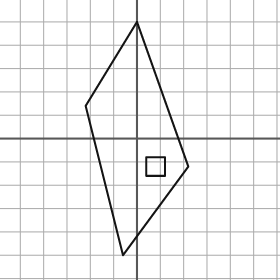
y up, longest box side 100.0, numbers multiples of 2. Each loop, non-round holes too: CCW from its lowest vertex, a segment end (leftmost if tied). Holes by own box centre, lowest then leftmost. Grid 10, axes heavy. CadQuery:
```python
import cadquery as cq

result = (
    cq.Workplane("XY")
    .moveTo(-6.0, -50.0)
    .lineTo(22.0, -12.0)
    .lineTo(0.0, 50.0)
    .lineTo(-22.0, 14.0)
    .close()
    .moveTo(4.0, -16.0)
    .lineTo(12.0, -16.0)
    .lineTo(12.0, -8.0)
    .lineTo(4.0, -8.0)
    .close()
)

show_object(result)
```